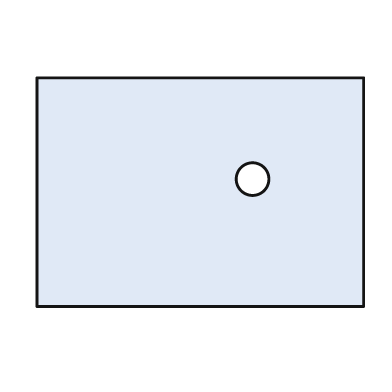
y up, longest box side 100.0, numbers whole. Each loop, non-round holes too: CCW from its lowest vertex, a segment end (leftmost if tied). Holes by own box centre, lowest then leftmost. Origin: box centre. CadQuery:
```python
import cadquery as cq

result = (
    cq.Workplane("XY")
    .moveTo(-50.0, -35.0)
    .lineTo(50.0, -35.0)
    .lineTo(50.0, 35.0)
    .lineTo(-50.0, 35.0)
    .close()
    .moveTo(16.0, 4.0)
    .circle(5.0)
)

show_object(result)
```